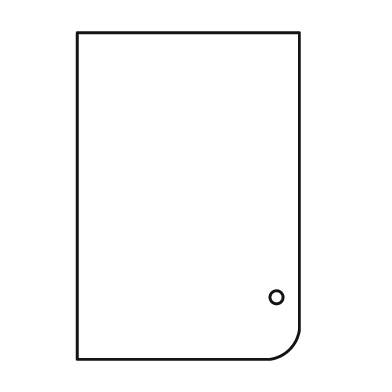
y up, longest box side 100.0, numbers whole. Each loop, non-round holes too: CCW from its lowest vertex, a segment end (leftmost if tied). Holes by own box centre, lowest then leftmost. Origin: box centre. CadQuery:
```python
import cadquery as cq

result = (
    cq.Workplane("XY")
    .moveTo(-34.0, -50.0)
    .lineTo(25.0, -50.0)
    .threePointArc((31.0, -47.0), (34.0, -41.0))
    .lineTo(34.0, 50.0)
    .lineTo(-34.0, 50.0)
    .close()
    .moveTo(27.0, -31.0)
    .circle(2.0)
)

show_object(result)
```